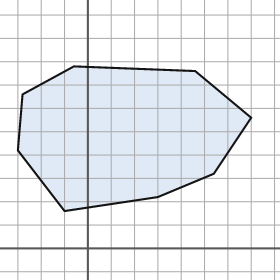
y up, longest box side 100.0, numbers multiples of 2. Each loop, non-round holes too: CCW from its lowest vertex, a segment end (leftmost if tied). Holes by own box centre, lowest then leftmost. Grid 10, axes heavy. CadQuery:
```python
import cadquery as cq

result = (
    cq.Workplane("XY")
    .moveTo(-10.0, 16.0)
    .lineTo(30.0, 22.0)
    .lineTo(54.0, 32.0)
    .lineTo(70.0, 56.0)
    .lineTo(46.0, 76.0)
    .lineTo(-6.0, 78.0)
    .lineTo(-28.0, 66.0)
    .lineTo(-30.0, 42.0)
    .close()
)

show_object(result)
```